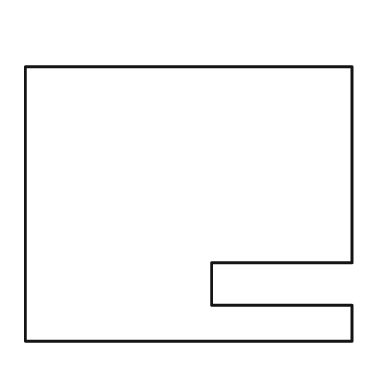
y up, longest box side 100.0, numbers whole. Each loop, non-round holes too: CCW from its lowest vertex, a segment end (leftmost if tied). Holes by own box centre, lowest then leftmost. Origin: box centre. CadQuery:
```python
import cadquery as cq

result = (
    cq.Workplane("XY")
    .moveTo(-50.0, -42.0)
    .lineTo(50.0, -42.0)
    .lineTo(50.0, -31.0)
    .lineTo(7.0, -31.0)
    .lineTo(7.0, -18.0)
    .lineTo(50.0, -18.0)
    .lineTo(50.0, 42.0)
    .lineTo(-50.0, 42.0)
    .close()
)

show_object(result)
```